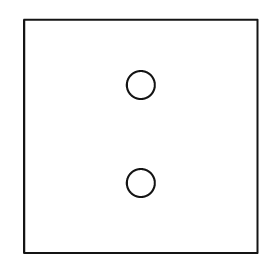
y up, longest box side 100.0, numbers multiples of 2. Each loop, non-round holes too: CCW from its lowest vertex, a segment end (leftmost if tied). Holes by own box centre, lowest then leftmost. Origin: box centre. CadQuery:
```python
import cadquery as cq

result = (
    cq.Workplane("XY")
    .moveTo(-50.0, -50.0)
    .lineTo(50.0, -50.0)
    .lineTo(50.0, 50.0)
    .lineTo(-50.0, 50.0)
    .close()
    .moveTo(0.0, -20.0)
    .circle(6.0)
    .moveTo(0.0, 22.0)
    .circle(6.0)
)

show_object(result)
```